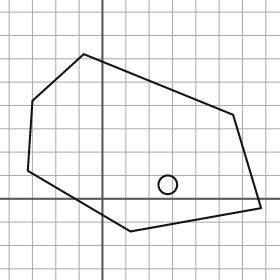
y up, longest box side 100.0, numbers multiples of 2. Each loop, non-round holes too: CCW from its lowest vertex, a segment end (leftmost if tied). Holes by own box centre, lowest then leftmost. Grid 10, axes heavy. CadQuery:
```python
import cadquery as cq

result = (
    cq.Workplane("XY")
    .moveTo(12.0, -14.0)
    .lineTo(68.0, -4.0)
    .lineTo(56.0, 36.0)
    .lineTo(-8.0, 62.0)
    .lineTo(-30.0, 42.0)
    .lineTo(-32.0, 12.0)
    .close()
    .moveTo(28.0, 6.0)
    .circle(4.0)
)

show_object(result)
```